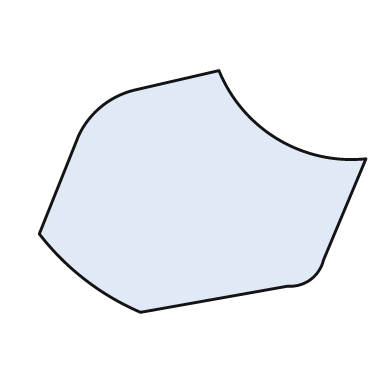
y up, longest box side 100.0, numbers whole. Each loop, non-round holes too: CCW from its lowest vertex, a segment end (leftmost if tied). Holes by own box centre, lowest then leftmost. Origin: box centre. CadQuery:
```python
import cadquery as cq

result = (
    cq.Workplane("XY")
    .moveTo(-19.0, -37.0)
    .lineTo(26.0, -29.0)
    .threePointArc((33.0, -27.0), (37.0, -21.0))
    .lineTo(50.0, 10.0)
    .threePointArc((23.0, 16.0), (5.0, 37.0))
    .lineTo(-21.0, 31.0)
    .threePointArc((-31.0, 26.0), (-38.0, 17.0))
    .lineTo(-50.0, -13.0)
    .threePointArc((-36.0, -27.0), (-19.0, -37.0))
    .close()
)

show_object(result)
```